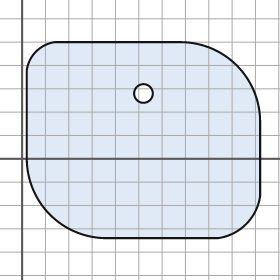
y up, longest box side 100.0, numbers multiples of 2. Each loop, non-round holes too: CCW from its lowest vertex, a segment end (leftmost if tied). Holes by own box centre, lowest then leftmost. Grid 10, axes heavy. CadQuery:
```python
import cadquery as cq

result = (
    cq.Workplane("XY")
    .moveTo(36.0, -34.0)
    .lineTo(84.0, -34.0)
    .threePointArc((96.0, -28.0), (102.0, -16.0))
    .lineTo(102.0, 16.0)
    .threePointArc((92.0, 40.0), (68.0, 50.0))
    .lineTo(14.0, 50.0)
    .threePointArc((6.0, 46.0), (2.0, 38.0))
    .lineTo(2.0, 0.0)
    .threePointArc((12.0, -24.0), (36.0, -34.0))
    .close()
    .moveTo(52.0, 28.0)
    .circle(4.0)
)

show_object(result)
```